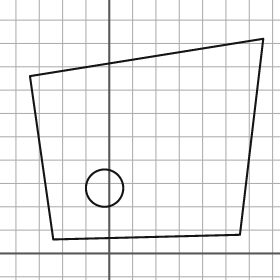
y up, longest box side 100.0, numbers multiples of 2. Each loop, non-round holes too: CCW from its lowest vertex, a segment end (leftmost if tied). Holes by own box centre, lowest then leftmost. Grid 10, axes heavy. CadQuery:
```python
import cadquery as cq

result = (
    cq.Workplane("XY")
    .moveTo(-24.0, 6.0)
    .lineTo(56.0, 8.0)
    .lineTo(66.0, 92.0)
    .lineTo(-34.0, 76.0)
    .close()
    .moveTo(-2.0, 28.0)
    .circle(8.0)
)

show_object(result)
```